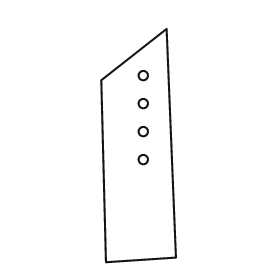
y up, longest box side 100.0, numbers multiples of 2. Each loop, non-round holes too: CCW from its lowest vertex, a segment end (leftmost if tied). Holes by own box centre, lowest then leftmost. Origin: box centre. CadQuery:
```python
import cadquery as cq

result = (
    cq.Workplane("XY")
    .moveTo(-14.0, -50.0)
    .lineTo(16.0, -48.0)
    .lineTo(12.0, 50.0)
    .lineTo(-16.0, 28.0)
    .close()
    .moveTo(2.0, -6.0)
    .circle(2.0)
    .moveTo(2.0, 6.0)
    .circle(2.0)
    .moveTo(2.0, 18.0)
    .circle(2.0)
    .moveTo(2.0, 30.0)
    .circle(2.0)
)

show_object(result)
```